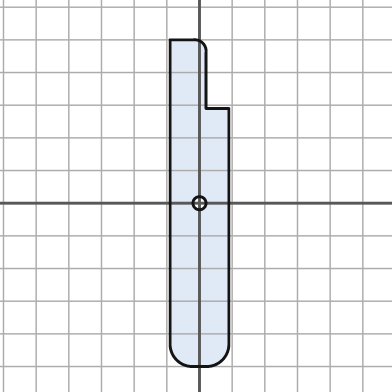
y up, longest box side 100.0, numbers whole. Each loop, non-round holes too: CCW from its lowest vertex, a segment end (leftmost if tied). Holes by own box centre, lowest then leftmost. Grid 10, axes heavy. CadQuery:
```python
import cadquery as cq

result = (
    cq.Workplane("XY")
    .moveTo(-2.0, -50.0)
    .lineTo(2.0, -50.0)
    .threePointArc((7.0, -48.0), (9.0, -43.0))
    .lineTo(9.0, 29.0)
    .lineTo(2.0, 29.0)
    .lineTo(2.0, 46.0)
    .threePointArc((1.0, 49.0), (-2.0, 50.0))
    .lineTo(-9.0, 50.0)
    .lineTo(-9.0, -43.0)
    .threePointArc((-7.0, -48.0), (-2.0, -50.0))
    .close()
    .moveTo(0.0, 0.0)
    .circle(2.0)
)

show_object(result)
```